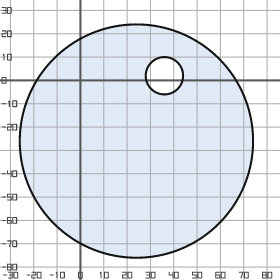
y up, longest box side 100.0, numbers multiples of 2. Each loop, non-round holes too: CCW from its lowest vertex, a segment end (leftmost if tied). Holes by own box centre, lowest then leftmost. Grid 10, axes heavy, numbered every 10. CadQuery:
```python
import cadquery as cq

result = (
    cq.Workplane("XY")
    .moveTo(24.0, -26.0)
    .circle(50.0)
    .moveTo(36.0, 2.0)
    .circle(8.0)
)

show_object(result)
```